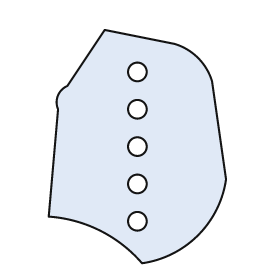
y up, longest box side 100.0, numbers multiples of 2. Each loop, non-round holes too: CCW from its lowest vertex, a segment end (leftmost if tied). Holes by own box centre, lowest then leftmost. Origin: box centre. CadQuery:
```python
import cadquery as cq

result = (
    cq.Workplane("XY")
    .moveTo(2.0, -50.0)
    .threePointArc((26.0, -38.0), (38.0, -14.0))
    .lineTo(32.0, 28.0)
    .threePointArc((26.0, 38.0), (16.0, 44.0))
    .lineTo(-14.0, 50.0)
    .lineTo(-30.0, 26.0)
    .threePointArc((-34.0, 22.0), (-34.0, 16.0))
    .lineTo(-38.0, -30.0)
    .threePointArc((-16.0, -36.0), (2.0, -50.0))
    .close()
    .moveTo(0.0, -32.0)
    .circle(4.0)
    .moveTo(0.0, -16.0)
    .circle(4.0)
    .moveTo(0.0, 0.0)
    .circle(4.0)
    .moveTo(0.0, 16.0)
    .circle(4.0)
    .moveTo(0.0, 32.0)
    .circle(4.0)
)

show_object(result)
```